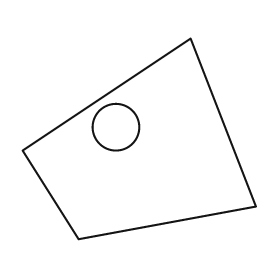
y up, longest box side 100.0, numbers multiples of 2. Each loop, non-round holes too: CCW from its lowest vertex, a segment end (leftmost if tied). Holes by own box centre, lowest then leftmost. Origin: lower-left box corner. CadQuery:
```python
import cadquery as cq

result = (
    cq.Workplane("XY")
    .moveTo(24.0, 0.0)
    .lineTo(100.0, 14.0)
    .lineTo(72.0, 86.0)
    .lineTo(0.0, 38.0)
    .close()
    .moveTo(40.0, 48.0)
    .circle(10.0)
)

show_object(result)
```